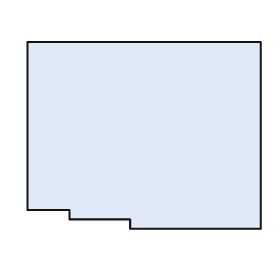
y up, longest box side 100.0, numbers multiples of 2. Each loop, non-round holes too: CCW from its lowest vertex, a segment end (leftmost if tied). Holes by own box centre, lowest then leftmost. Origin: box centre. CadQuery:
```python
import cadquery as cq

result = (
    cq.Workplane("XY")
    .moveTo(-6.0, -40.0)
    .lineTo(50.0, -40.0)
    .lineTo(50.0, 40.0)
    .lineTo(-50.0, 40.0)
    .lineTo(-50.0, -32.0)
    .lineTo(-32.0, -32.0)
    .lineTo(-32.0, -36.0)
    .lineTo(-6.0, -36.0)
    .close()
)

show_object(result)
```